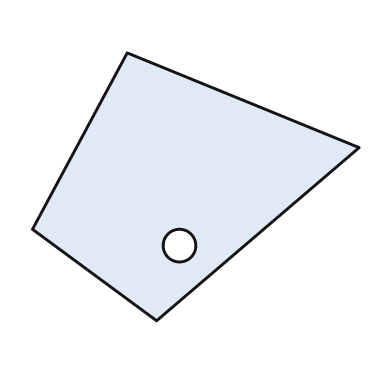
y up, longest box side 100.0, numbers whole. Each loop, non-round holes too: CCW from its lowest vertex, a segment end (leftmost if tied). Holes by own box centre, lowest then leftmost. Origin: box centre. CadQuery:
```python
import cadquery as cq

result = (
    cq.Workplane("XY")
    .moveTo(-12.0, -41.0)
    .lineTo(50.0, 12.0)
    .lineTo(-21.0, 41.0)
    .lineTo(-50.0, -13.0)
    .close()
    .moveTo(-5.0, -18.0)
    .circle(5.0)
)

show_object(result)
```